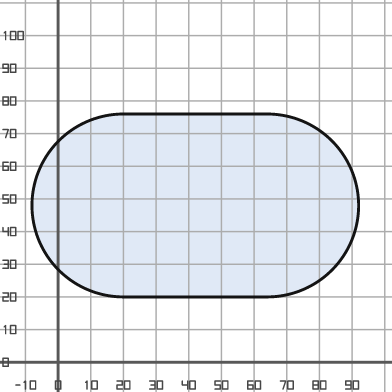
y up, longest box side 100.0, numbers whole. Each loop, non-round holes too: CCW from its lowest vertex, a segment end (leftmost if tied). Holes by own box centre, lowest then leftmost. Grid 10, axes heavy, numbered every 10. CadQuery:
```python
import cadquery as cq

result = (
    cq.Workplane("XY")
    .moveTo(20.0, 20.0)
    .lineTo(64.0, 20.0)
    .threePointArc((92.0, 48.0), (64.0, 76.0))
    .lineTo(20.0, 76.0)
    .threePointArc((-8.0, 48.0), (20.0, 20.0))
    .close()
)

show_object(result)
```